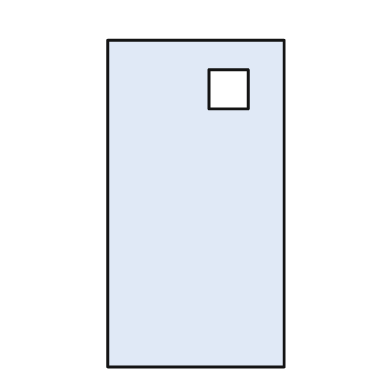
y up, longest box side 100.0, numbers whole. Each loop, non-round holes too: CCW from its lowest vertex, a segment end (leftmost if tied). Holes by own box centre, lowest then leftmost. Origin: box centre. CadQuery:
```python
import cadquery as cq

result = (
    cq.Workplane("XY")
    .moveTo(-27.0, -50.0)
    .lineTo(27.0, -50.0)
    .lineTo(27.0, 50.0)
    .lineTo(-27.0, 50.0)
    .close()
    .moveTo(4.0, 29.0)
    .lineTo(16.0, 29.0)
    .lineTo(16.0, 41.0)
    .lineTo(4.0, 41.0)
    .close()
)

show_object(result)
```